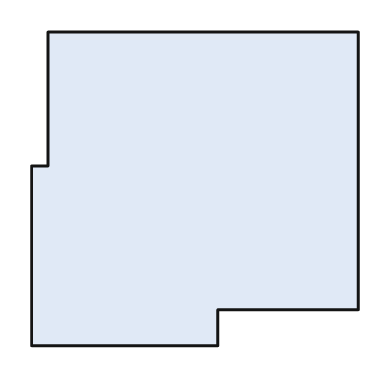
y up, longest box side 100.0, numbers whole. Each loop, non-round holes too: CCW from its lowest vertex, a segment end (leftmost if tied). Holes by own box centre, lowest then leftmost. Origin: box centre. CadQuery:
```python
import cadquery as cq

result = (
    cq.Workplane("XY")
    .moveTo(-50.0, -48.0)
    .lineTo(7.0, -48.0)
    .lineTo(7.0, -37.0)
    .lineTo(50.0, -37.0)
    .lineTo(50.0, 48.0)
    .lineTo(-45.0, 48.0)
    .lineTo(-45.0, 7.0)
    .lineTo(-50.0, 7.0)
    .close()
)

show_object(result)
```